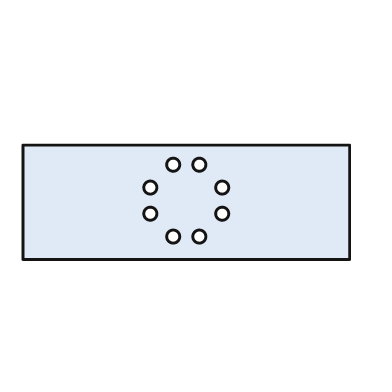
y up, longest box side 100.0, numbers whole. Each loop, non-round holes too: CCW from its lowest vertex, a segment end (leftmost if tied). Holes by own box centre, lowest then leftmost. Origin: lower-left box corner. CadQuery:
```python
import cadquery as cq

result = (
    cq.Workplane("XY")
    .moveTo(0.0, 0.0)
    .lineTo(100.0, 0.0)
    .lineTo(100.0, 35.0)
    .lineTo(0.0, 35.0)
    .close()
    .moveTo(46.0, 7.0)
    .circle(2.0)
    .moveTo(54.0, 7.0)
    .circle(2.0)
    .moveTo(39.0, 14.0)
    .circle(2.0)
    .moveTo(61.0, 14.0)
    .circle(2.0)
    .moveTo(39.0, 22.0)
    .circle(2.0)
    .moveTo(61.0, 22.0)
    .circle(2.0)
    .moveTo(46.0, 29.0)
    .circle(2.0)
    .moveTo(54.0, 29.0)
    .circle(2.0)
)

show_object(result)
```